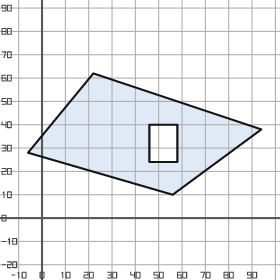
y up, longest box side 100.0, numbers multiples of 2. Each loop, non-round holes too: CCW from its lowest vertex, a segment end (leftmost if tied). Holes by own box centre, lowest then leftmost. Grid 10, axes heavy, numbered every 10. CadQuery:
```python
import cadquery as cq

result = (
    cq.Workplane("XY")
    .moveTo(56.0, 10.0)
    .lineTo(94.0, 38.0)
    .lineTo(22.0, 62.0)
    .lineTo(-6.0, 28.0)
    .close()
    .moveTo(46.0, 24.0)
    .lineTo(58.0, 24.0)
    .lineTo(58.0, 40.0)
    .lineTo(46.0, 40.0)
    .close()
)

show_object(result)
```